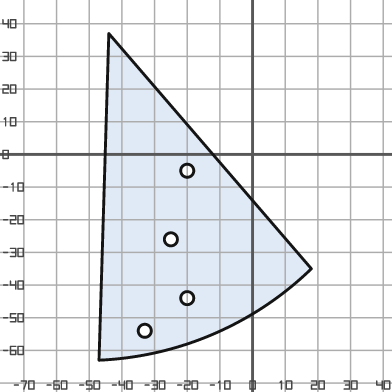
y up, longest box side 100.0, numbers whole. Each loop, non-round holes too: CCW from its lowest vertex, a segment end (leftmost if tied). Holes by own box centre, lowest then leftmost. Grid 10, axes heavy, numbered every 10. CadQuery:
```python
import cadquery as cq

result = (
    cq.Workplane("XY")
    .moveTo(-47.0, -63.0)
    .threePointArc((-12.0, -55.0), (18.0, -35.0))
    .lineTo(-44.0, 37.0)
    .close()
    .moveTo(-33.0, -54.0)
    .circle(2.0)
    .moveTo(-20.0, -44.0)
    .circle(2.0)
    .moveTo(-25.0, -26.0)
    .circle(2.0)
    .moveTo(-20.0, -5.0)
    .circle(2.0)
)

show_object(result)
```